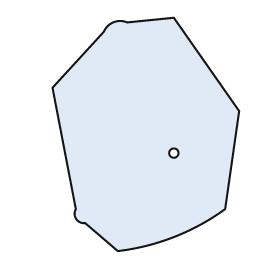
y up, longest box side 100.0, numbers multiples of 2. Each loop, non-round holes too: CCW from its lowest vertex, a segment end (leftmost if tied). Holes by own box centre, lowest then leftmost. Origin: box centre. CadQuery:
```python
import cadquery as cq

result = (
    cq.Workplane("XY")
    .moveTo(-12.0, -50.0)
    .threePointArc((12.0, -44.0), (34.0, -32.0))
    .lineTo(40.0, 10.0)
    .lineTo(12.0, 50.0)
    .lineTo(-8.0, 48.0)
    .threePointArc((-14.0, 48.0), (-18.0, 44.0))
    .lineTo(-40.0, 20.0)
    .lineTo(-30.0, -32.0)
    .threePointArc((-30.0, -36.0), (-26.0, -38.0))
    .close()
    .moveTo(12.0, -8.0)
    .circle(2.0)
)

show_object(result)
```